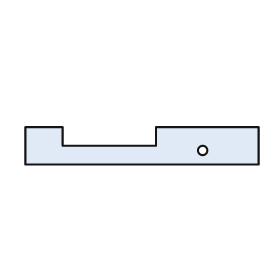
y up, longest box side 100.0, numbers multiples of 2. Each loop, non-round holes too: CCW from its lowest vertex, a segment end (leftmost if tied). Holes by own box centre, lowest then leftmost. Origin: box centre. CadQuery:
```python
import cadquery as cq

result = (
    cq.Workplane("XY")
    .moveTo(-50.0, -8.0)
    .lineTo(50.0, -8.0)
    .lineTo(50.0, 8.0)
    .lineTo(6.0, 8.0)
    .lineTo(6.0, 0.0)
    .lineTo(-34.0, 0.0)
    .lineTo(-34.0, 8.0)
    .lineTo(-50.0, 8.0)
    .close()
    .moveTo(26.0, -2.0)
    .circle(2.0)
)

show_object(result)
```